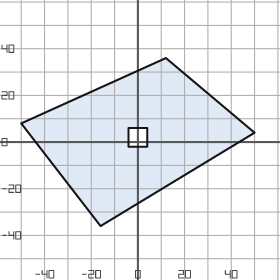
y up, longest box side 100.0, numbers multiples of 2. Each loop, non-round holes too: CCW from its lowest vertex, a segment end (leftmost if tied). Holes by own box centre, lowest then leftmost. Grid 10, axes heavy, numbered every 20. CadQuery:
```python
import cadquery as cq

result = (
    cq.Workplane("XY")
    .moveTo(-16.0, -36.0)
    .lineTo(50.0, 4.0)
    .lineTo(12.0, 36.0)
    .lineTo(-50.0, 8.0)
    .close()
    .moveTo(-4.0, -2.0)
    .lineTo(4.0, -2.0)
    .lineTo(4.0, 6.0)
    .lineTo(-4.0, 6.0)
    .close()
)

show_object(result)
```